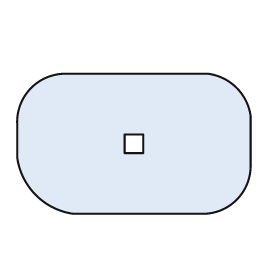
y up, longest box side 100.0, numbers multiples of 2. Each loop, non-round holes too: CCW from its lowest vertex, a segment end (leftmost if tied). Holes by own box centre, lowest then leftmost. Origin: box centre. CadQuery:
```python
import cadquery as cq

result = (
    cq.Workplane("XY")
    .moveTo(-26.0, -30.0)
    .lineTo(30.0, -30.0)
    .threePointArc((44.0, -24.0), (50.0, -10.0))
    .lineTo(50.0, 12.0)
    .threePointArc((44.0, 24.0), (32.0, 30.0))
    .lineTo(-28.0, 30.0)
    .threePointArc((-44.0, 24.0), (-50.0, 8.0))
    .lineTo(-50.0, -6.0)
    .threePointArc((-42.0, -22.0), (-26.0, -30.0))
    .close()
    .moveTo(-4.0, -4.0)
    .lineTo(4.0, -4.0)
    .lineTo(4.0, 4.0)
    .lineTo(-4.0, 4.0)
    .close()
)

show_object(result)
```